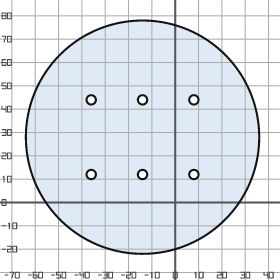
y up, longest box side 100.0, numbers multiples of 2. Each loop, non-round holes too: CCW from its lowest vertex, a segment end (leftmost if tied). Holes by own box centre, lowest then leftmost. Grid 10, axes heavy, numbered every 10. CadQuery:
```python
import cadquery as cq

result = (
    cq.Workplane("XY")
    .moveTo(-14.0, 28.0)
    .circle(50.0)
    .moveTo(-36.0, 12.0)
    .circle(2.0)
    .moveTo(-14.0, 12.0)
    .circle(2.0)
    .moveTo(8.0, 12.0)
    .circle(2.0)
    .moveTo(-36.0, 44.0)
    .circle(2.0)
    .moveTo(-14.0, 44.0)
    .circle(2.0)
    .moveTo(8.0, 44.0)
    .circle(2.0)
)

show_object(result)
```